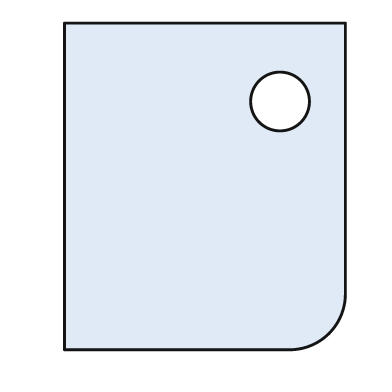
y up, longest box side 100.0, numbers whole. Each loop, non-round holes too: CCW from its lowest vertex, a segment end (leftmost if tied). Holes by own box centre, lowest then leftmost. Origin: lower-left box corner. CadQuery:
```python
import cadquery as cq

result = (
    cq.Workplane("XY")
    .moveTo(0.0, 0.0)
    .lineTo(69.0, 0.0)
    .threePointArc((81.0, 5.0), (86.0, 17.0))
    .lineTo(86.0, 100.0)
    .lineTo(0.0, 100.0)
    .close()
    .moveTo(66.0, 76.0)
    .circle(9.0)
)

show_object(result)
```